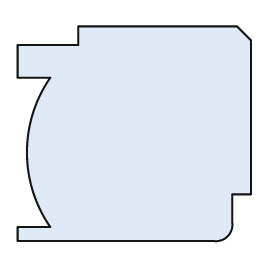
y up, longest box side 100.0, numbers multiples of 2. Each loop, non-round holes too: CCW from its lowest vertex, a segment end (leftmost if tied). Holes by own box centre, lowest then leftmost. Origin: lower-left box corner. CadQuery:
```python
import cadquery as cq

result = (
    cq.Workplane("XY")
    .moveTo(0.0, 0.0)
    .lineTo(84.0, 0.0)
    .threePointArc((90.0, 2.0), (92.0, 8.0))
    .lineTo(92.0, 20.0)
    .lineTo(100.0, 20.0)
    .lineTo(100.0, 86.0)
    .lineTo(94.0, 92.0)
    .lineTo(26.0, 92.0)
    .lineTo(26.0, 84.0)
    .lineTo(0.0, 84.0)
    .lineTo(0.0, 70.0)
    .lineTo(14.0, 70.0)
    .threePointArc((4.0, 38.0), (14.0, 6.0))
    .lineTo(0.0, 6.0)
    .close()
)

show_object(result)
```